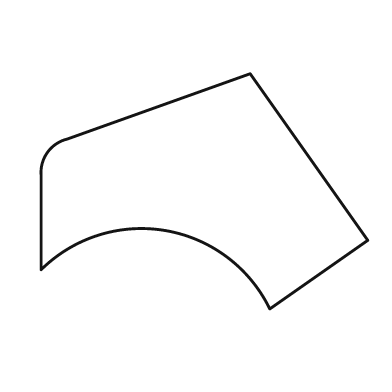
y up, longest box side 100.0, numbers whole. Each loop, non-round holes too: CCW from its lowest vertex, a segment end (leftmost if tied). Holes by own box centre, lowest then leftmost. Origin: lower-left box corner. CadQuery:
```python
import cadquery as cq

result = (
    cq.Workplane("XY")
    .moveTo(70.0, 0.0)
    .lineTo(100.0, 21.0)
    .lineTo(64.0, 72.0)
    .lineTo(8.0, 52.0)
    .threePointArc((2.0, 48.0), (0.0, 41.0))
    .lineTo(0.0, 12.0)
    .threePointArc((38.0, 24.0), (70.0, 0.0))
    .close()
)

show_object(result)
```